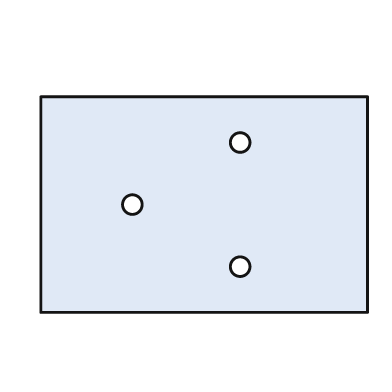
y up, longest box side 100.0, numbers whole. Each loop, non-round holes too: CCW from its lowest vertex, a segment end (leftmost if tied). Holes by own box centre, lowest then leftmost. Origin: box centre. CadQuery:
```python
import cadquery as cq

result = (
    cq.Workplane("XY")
    .moveTo(-50.0, -33.0)
    .lineTo(50.0, -33.0)
    .lineTo(50.0, 33.0)
    .lineTo(-50.0, 33.0)
    .close()
    .moveTo(11.0, -19.0)
    .circle(3.0)
    .moveTo(-22.0, 0.0)
    .circle(3.0)
    .moveTo(11.0, 19.0)
    .circle(3.0)
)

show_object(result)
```